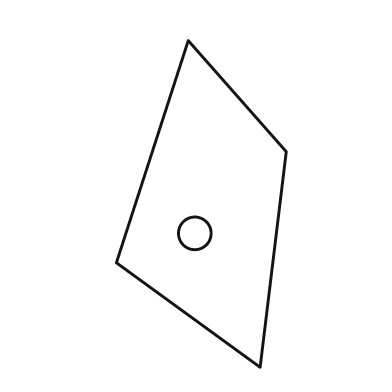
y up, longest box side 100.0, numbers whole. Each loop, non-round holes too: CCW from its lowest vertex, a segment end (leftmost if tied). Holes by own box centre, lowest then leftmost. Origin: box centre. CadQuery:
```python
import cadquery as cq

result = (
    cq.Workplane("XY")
    .moveTo(18.0, -50.0)
    .lineTo(26.0, 16.0)
    .lineTo(-4.0, 50.0)
    .lineTo(-26.0, -18.0)
    .close()
    .moveTo(-2.0, -9.0)
    .circle(5.0)
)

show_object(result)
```